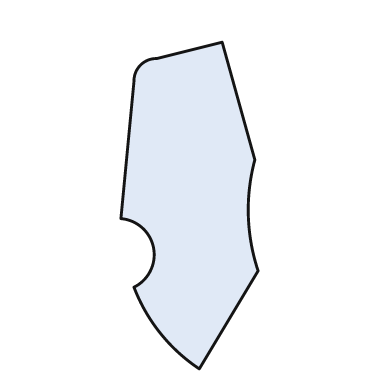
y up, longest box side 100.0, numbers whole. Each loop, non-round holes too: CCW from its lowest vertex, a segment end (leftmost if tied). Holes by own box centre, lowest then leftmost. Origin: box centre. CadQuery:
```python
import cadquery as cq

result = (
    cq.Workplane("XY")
    .moveTo(3.0, -50.0)
    .lineTo(21.0, -20.0)
    .threePointArc((18.0, -3.0), (20.0, 14.0))
    .lineTo(10.0, 50.0)
    .lineTo(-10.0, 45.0)
    .threePointArc((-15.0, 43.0), (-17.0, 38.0))
    .lineTo(-21.0, -4.0)
    .threePointArc((-11.0, -13.0), (-17.0, -25.0))
    .threePointArc((-9.0, -39.0), (3.0, -50.0))
    .close()
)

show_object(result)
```